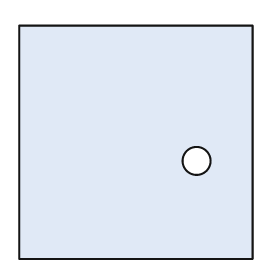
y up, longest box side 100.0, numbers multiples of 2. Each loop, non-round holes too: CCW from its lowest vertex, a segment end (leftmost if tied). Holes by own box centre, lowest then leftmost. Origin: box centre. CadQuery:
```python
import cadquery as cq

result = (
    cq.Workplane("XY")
    .moveTo(-50.0, -50.0)
    .lineTo(50.0, -50.0)
    .lineTo(50.0, 50.0)
    .lineTo(-50.0, 50.0)
    .close()
    .moveTo(26.0, -8.0)
    .circle(6.0)
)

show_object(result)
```